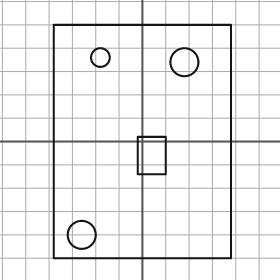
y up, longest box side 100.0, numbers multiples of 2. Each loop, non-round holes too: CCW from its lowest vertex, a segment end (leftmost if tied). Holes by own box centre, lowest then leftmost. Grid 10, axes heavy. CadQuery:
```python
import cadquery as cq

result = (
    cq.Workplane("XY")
    .moveTo(-38.0, -50.0)
    .lineTo(38.0, -50.0)
    .lineTo(38.0, 50.0)
    .lineTo(-38.0, 50.0)
    .close()
    .moveTo(-26.0, -40.0)
    .circle(6.0)
    .moveTo(-2.0, -14.0)
    .lineTo(10.0, -14.0)
    .lineTo(10.0, 2.0)
    .lineTo(-2.0, 2.0)
    .close()
    .moveTo(18.0, 34.0)
    .circle(6.0)
    .moveTo(-18.0, 36.0)
    .circle(4.0)
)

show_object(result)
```